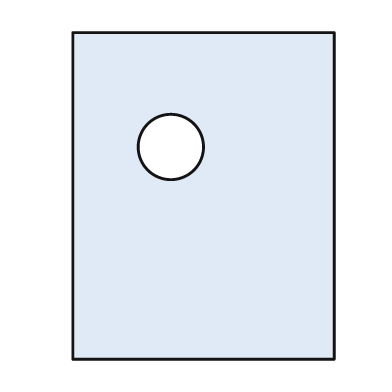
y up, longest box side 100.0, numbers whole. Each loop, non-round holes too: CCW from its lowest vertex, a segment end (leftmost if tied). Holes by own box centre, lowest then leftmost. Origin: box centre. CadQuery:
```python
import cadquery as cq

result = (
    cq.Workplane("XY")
    .moveTo(-40.0, -50.0)
    .lineTo(40.0, -50.0)
    .lineTo(40.0, 50.0)
    .lineTo(-40.0, 50.0)
    .close()
    .moveTo(-10.0, 15.0)
    .circle(10.0)
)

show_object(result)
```